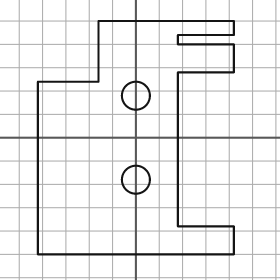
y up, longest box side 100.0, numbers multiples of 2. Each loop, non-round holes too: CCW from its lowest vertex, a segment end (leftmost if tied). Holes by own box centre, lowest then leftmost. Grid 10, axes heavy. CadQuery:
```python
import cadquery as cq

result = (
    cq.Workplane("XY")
    .moveTo(-42.0, -50.0)
    .lineTo(42.0, -50.0)
    .lineTo(42.0, -38.0)
    .lineTo(18.0, -38.0)
    .lineTo(18.0, 28.0)
    .lineTo(42.0, 28.0)
    .lineTo(42.0, 40.0)
    .lineTo(18.0, 40.0)
    .lineTo(18.0, 44.0)
    .lineTo(42.0, 44.0)
    .lineTo(42.0, 50.0)
    .lineTo(-16.0, 50.0)
    .lineTo(-16.0, 24.0)
    .lineTo(-42.0, 24.0)
    .close()
    .moveTo(0.0, -18.0)
    .circle(6.0)
    .moveTo(0.0, 18.0)
    .circle(6.0)
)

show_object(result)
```